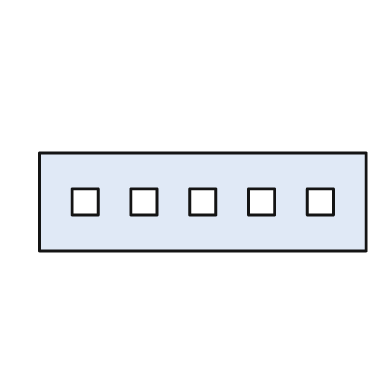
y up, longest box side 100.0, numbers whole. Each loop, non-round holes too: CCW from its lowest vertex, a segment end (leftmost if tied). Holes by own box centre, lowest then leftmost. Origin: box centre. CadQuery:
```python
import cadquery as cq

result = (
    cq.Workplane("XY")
    .moveTo(-50.0, -15.0)
    .lineTo(50.0, -15.0)
    .lineTo(50.0, 15.0)
    .lineTo(-50.0, 15.0)
    .close()
    .moveTo(-40.0, -4.0)
    .lineTo(-32.0, -4.0)
    .lineTo(-32.0, 4.0)
    .lineTo(-40.0, 4.0)
    .close()
    .moveTo(-22.0, -4.0)
    .lineTo(-14.0, -4.0)
    .lineTo(-14.0, 4.0)
    .lineTo(-22.0, 4.0)
    .close()
    .moveTo(-4.0, -4.0)
    .lineTo(4.0, -4.0)
    .lineTo(4.0, 4.0)
    .lineTo(-4.0, 4.0)
    .close()
    .moveTo(14.0, -4.0)
    .lineTo(22.0, -4.0)
    .lineTo(22.0, 4.0)
    .lineTo(14.0, 4.0)
    .close()
    .moveTo(32.0, -4.0)
    .lineTo(40.0, -4.0)
    .lineTo(40.0, 4.0)
    .lineTo(32.0, 4.0)
    .close()
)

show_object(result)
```